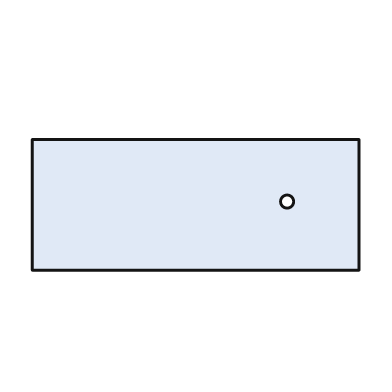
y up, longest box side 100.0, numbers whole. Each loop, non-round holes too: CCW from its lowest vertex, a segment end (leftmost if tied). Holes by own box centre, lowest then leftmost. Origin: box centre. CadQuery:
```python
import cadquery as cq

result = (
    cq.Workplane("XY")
    .moveTo(-50.0, -20.0)
    .lineTo(50.0, -20.0)
    .lineTo(50.0, 20.0)
    .lineTo(-50.0, 20.0)
    .close()
    .moveTo(28.0, 1.0)
    .circle(2.0)
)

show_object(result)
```